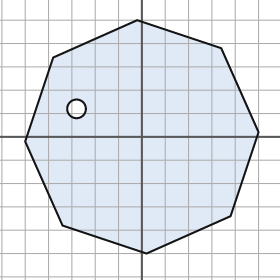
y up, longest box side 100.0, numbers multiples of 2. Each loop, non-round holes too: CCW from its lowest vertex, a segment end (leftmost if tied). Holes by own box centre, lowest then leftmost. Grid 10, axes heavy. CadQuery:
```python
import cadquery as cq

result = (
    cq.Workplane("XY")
    .moveTo(2.0, -50.0)
    .lineTo(38.0, -34.0)
    .lineTo(50.0, 2.0)
    .lineTo(34.0, 38.0)
    .lineTo(-2.0, 50.0)
    .lineTo(-38.0, 34.0)
    .lineTo(-50.0, -2.0)
    .lineTo(-34.0, -38.0)
    .close()
    .moveTo(-28.0, 12.0)
    .circle(4.0)
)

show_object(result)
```